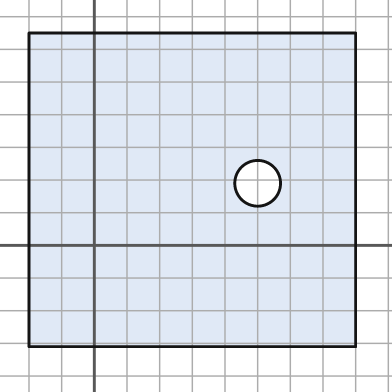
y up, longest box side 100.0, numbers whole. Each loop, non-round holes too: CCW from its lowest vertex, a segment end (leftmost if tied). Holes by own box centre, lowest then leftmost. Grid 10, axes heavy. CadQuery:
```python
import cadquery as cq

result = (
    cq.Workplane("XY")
    .moveTo(-20.0, -31.0)
    .lineTo(80.0, -31.0)
    .lineTo(80.0, 65.0)
    .lineTo(-20.0, 65.0)
    .close()
    .moveTo(50.0, 19.0)
    .circle(7.0)
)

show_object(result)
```